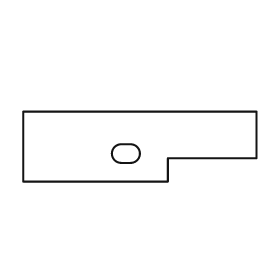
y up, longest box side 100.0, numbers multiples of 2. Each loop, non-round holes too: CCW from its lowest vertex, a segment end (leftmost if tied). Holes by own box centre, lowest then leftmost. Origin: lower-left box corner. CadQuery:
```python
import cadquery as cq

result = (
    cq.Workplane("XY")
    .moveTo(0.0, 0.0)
    .lineTo(62.0, 0.0)
    .lineTo(62.0, 10.0)
    .lineTo(100.0, 10.0)
    .lineTo(100.0, 30.0)
    .lineTo(0.0, 30.0)
    .close()
    .moveTo(42.0, 8.0)
    .lineTo(46.0, 8.0)
    .threePointArc((50.0, 12.0), (46.0, 16.0))
    .lineTo(42.0, 16.0)
    .threePointArc((38.0, 12.0), (42.0, 8.0))
    .close()
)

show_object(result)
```